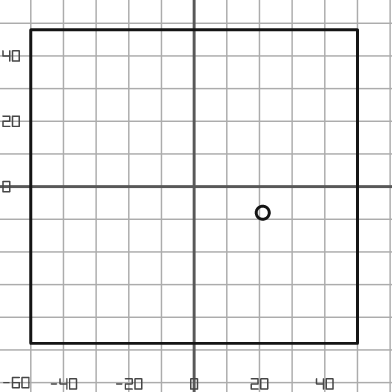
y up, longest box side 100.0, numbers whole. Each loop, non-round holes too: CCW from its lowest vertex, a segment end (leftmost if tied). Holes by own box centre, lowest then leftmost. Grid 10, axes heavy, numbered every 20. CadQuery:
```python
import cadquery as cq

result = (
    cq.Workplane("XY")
    .moveTo(-50.0, -48.0)
    .lineTo(50.0, -48.0)
    .lineTo(50.0, 48.0)
    .lineTo(-50.0, 48.0)
    .close()
    .moveTo(21.0, -8.0)
    .circle(2.0)
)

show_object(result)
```